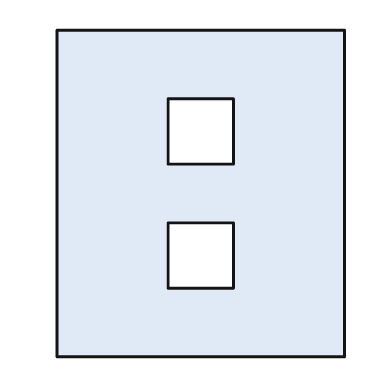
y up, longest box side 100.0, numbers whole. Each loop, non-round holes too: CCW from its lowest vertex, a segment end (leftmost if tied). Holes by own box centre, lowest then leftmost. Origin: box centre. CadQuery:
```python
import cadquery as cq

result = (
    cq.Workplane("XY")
    .moveTo(-44.0, -50.0)
    .lineTo(44.0, -50.0)
    .lineTo(44.0, 50.0)
    .lineTo(-44.0, 50.0)
    .close()
    .moveTo(-10.0, -29.0)
    .lineTo(10.0, -29.0)
    .lineTo(10.0, -9.0)
    .lineTo(-10.0, -9.0)
    .close()
    .moveTo(-10.0, 9.0)
    .lineTo(10.0, 9.0)
    .lineTo(10.0, 29.0)
    .lineTo(-10.0, 29.0)
    .close()
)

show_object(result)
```